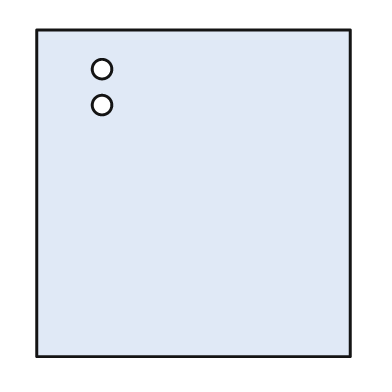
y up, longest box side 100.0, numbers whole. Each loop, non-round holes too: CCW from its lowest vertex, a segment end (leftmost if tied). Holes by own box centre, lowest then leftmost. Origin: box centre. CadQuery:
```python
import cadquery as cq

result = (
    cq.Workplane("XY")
    .moveTo(-48.0, -50.0)
    .lineTo(48.0, -50.0)
    .lineTo(48.0, 50.0)
    .lineTo(-48.0, 50.0)
    .close()
    .moveTo(-28.0, 27.0)
    .circle(3.0)
    .moveTo(-28.0, 38.0)
    .circle(3.0)
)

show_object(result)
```